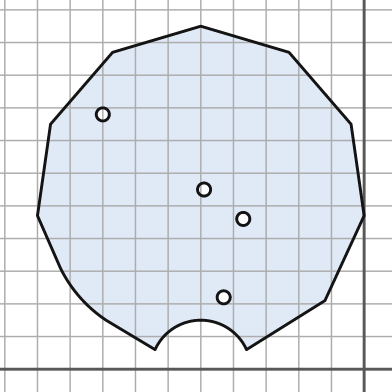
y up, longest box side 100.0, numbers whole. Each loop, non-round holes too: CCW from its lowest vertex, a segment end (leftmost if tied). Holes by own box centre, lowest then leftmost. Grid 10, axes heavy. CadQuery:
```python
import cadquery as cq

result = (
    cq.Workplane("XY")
    .moveTo(-64.0, 6.0)
    .threePointArc((-50.0, 15.0), (-36.0, 6.0))
    .lineTo(-12.0, 21.0)
    .lineTo(0.0, 47.0)
    .lineTo(-4.0, 75.0)
    .lineTo(-23.0, 97.0)
    .lineTo(-50.0, 105.0)
    .lineTo(-77.0, 97.0)
    .lineTo(-96.0, 75.0)
    .lineTo(-100.0, 47.0)
    .lineTo(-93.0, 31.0)
    .threePointArc((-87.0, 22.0), (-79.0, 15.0))
    .close()
    .moveTo(-43.0, 22.0)
    .circle(2.0)
    .moveTo(-37.0, 46.0)
    .circle(2.0)
    .moveTo(-49.0, 55.0)
    .circle(2.0)
    .moveTo(-80.0, 78.0)
    .circle(2.0)
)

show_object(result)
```